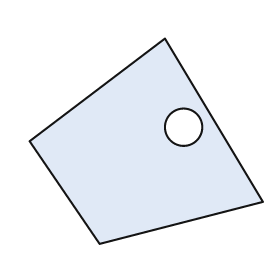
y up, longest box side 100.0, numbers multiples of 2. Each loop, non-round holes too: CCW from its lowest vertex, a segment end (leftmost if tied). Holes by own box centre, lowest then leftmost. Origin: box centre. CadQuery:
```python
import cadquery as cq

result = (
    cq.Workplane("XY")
    .moveTo(-20.0, -44.0)
    .lineTo(50.0, -26.0)
    .lineTo(8.0, 44.0)
    .lineTo(-50.0, 0.0)
    .close()
    .moveTo(16.0, 6.0)
    .circle(8.0)
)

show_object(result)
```